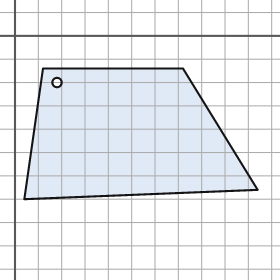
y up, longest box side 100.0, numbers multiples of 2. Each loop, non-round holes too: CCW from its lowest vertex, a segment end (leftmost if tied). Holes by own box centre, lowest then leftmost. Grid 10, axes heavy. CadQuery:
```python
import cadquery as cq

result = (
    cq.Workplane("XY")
    .moveTo(4.0, -70.0)
    .lineTo(104.0, -66.0)
    .lineTo(72.0, -14.0)
    .lineTo(12.0, -14.0)
    .close()
    .moveTo(18.0, -20.0)
    .circle(2.0)
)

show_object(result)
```